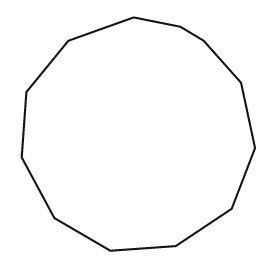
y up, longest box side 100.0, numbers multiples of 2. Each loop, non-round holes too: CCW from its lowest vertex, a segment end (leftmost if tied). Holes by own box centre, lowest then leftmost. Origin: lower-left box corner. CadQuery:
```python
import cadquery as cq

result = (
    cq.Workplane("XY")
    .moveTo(38.0, 0.0)
    .lineTo(66.0, 2.0)
    .lineTo(90.0, 18.0)
    .lineTo(100.0, 44.0)
    .lineTo(94.0, 72.0)
    .lineTo(78.0, 90.0)
    .lineTo(68.0, 96.0)
    .lineTo(48.0, 100.0)
    .lineTo(20.0, 90.0)
    .lineTo(2.0, 68.0)
    .lineTo(0.0, 40.0)
    .lineTo(14.0, 14.0)
    .close()
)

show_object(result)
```